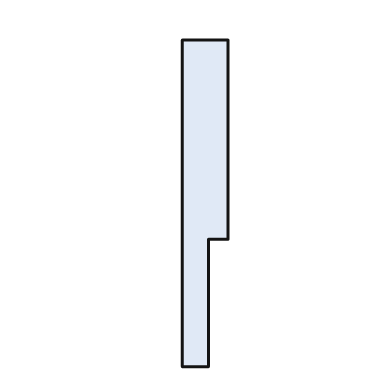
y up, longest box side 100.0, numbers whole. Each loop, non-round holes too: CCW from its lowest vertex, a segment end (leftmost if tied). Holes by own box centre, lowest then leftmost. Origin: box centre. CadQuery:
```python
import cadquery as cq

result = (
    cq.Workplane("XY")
    .moveTo(-7.0, -50.0)
    .lineTo(1.0, -50.0)
    .lineTo(1.0, -11.0)
    .lineTo(7.0, -11.0)
    .lineTo(7.0, 50.0)
    .lineTo(-7.0, 50.0)
    .close()
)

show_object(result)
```